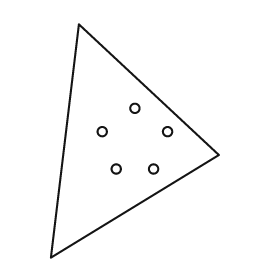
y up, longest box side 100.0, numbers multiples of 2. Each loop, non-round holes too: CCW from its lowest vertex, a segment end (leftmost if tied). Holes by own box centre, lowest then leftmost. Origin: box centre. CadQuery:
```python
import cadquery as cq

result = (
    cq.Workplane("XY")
    .moveTo(-36.0, -50.0)
    .lineTo(36.0, -6.0)
    .lineTo(-24.0, 50.0)
    .close()
    .moveTo(-8.0, -12.0)
    .circle(2.0)
    .moveTo(8.0, -12.0)
    .circle(2.0)
    .moveTo(-14.0, 4.0)
    .circle(2.0)
    .moveTo(14.0, 4.0)
    .circle(2.0)
    .moveTo(0.0, 14.0)
    .circle(2.0)
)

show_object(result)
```